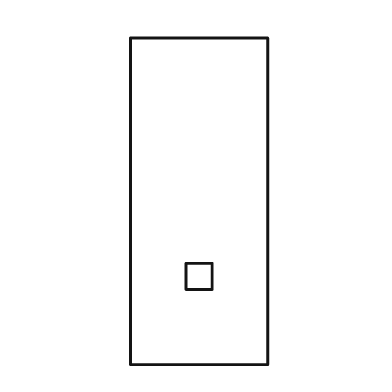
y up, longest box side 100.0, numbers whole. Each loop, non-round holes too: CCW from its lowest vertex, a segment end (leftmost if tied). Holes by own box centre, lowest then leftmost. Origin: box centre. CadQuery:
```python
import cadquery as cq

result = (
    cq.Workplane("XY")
    .moveTo(-21.0, -50.0)
    .lineTo(21.0, -50.0)
    .lineTo(21.0, 50.0)
    .lineTo(-21.0, 50.0)
    .close()
    .moveTo(-4.0, -27.0)
    .lineTo(4.0, -27.0)
    .lineTo(4.0, -19.0)
    .lineTo(-4.0, -19.0)
    .close()
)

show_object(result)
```